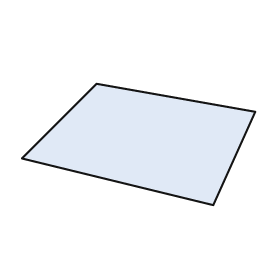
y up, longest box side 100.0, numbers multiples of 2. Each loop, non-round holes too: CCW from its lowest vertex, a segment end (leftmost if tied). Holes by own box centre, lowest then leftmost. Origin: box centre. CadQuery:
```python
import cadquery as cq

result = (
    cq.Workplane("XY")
    .moveTo(32.0, -26.0)
    .lineTo(50.0, 14.0)
    .lineTo(-18.0, 26.0)
    .lineTo(-50.0, -6.0)
    .close()
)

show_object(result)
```